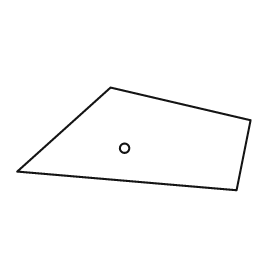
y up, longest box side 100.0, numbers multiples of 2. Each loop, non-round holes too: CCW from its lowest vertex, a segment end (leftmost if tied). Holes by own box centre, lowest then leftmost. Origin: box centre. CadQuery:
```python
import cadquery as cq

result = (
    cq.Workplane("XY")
    .moveTo(44.0, -22.0)
    .lineTo(50.0, 8.0)
    .lineTo(-10.0, 22.0)
    .lineTo(-50.0, -14.0)
    .close()
    .moveTo(-4.0, -4.0)
    .circle(2.0)
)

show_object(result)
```